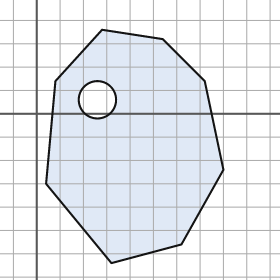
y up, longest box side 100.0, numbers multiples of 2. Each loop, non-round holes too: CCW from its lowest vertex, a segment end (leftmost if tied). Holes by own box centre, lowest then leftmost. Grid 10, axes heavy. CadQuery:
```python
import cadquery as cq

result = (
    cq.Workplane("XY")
    .moveTo(32.0, -64.0)
    .lineTo(62.0, -56.0)
    .lineTo(80.0, -24.0)
    .lineTo(72.0, 14.0)
    .lineTo(54.0, 32.0)
    .lineTo(28.0, 36.0)
    .lineTo(8.0, 14.0)
    .lineTo(4.0, -30.0)
    .close()
    .moveTo(26.0, 6.0)
    .circle(8.0)
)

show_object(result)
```